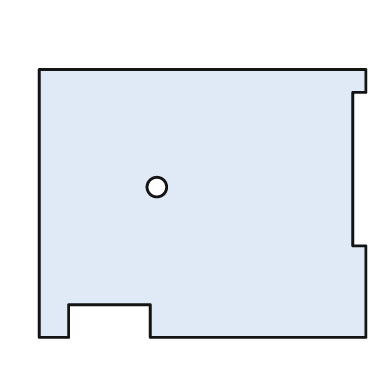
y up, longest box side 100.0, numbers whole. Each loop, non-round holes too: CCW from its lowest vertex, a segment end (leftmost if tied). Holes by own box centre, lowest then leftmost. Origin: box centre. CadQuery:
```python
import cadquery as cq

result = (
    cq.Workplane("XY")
    .moveTo(-50.0, -41.0)
    .lineTo(-41.0, -41.0)
    .lineTo(-41.0, -31.0)
    .lineTo(-16.0, -31.0)
    .lineTo(-16.0, -41.0)
    .lineTo(50.0, -41.0)
    .lineTo(50.0, -13.0)
    .lineTo(46.0, -13.0)
    .lineTo(46.0, 34.0)
    .lineTo(50.0, 34.0)
    .lineTo(50.0, 41.0)
    .lineTo(-50.0, 41.0)
    .close()
    .moveTo(-14.0, 5.0)
    .circle(3.0)
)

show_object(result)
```